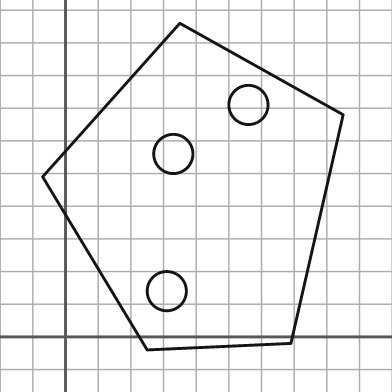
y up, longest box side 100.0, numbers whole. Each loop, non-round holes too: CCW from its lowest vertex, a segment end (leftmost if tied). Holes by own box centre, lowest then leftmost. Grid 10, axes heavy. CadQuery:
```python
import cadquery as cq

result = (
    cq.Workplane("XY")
    .moveTo(25.0, -4.0)
    .lineTo(69.0, -2.0)
    .lineTo(85.0, 68.0)
    .lineTo(35.0, 96.0)
    .lineTo(-7.0, 49.0)
    .close()
    .moveTo(31.0, 14.0)
    .circle(6.0)
    .moveTo(33.0, 56.0)
    .circle(6.0)
    .moveTo(56.0, 71.0)
    .circle(6.0)
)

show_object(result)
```